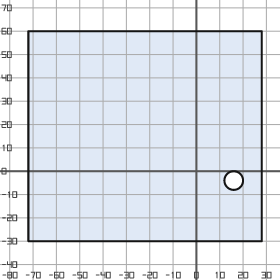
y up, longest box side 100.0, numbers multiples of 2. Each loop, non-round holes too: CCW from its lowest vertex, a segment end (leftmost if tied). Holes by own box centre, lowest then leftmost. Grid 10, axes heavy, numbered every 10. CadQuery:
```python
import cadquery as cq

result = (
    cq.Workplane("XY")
    .moveTo(-72.0, -30.0)
    .lineTo(28.0, -30.0)
    .lineTo(28.0, 60.0)
    .lineTo(-72.0, 60.0)
    .close()
    .moveTo(16.0, -4.0)
    .circle(4.0)
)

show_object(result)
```